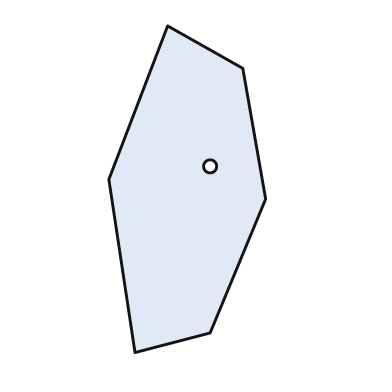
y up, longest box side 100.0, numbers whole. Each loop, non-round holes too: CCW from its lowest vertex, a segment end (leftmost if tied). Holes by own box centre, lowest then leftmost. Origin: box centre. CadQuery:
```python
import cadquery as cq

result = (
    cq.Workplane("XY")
    .moveTo(-16.0, -50.0)
    .lineTo(7.0, -44.0)
    .lineTo(24.0, -3.0)
    .lineTo(17.0, 37.0)
    .lineTo(-6.0, 50.0)
    .lineTo(-24.0, 3.0)
    .close()
    .moveTo(7.0, 7.0)
    .circle(2.0)
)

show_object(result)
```